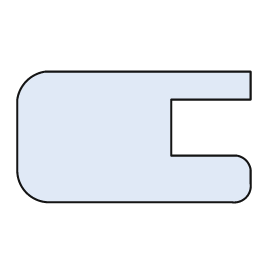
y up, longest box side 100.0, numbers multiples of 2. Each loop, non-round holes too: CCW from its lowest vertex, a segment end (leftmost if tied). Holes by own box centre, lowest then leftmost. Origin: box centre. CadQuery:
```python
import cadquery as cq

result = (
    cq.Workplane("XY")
    .moveTo(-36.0, -28.0)
    .lineTo(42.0, -28.0)
    .threePointArc((48.0, -26.0), (50.0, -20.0))
    .lineTo(50.0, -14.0)
    .threePointArc((48.0, -10.0), (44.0, -8.0))
    .lineTo(16.0, -8.0)
    .lineTo(16.0, 16.0)
    .lineTo(50.0, 16.0)
    .lineTo(50.0, 28.0)
    .lineTo(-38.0, 28.0)
    .threePointArc((-46.0, 24.0), (-50.0, 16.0))
    .lineTo(-50.0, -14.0)
    .threePointArc((-46.0, -24.0), (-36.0, -28.0))
    .close()
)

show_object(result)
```